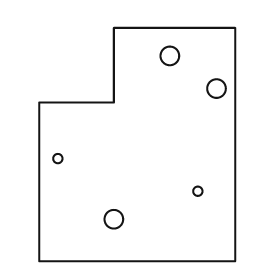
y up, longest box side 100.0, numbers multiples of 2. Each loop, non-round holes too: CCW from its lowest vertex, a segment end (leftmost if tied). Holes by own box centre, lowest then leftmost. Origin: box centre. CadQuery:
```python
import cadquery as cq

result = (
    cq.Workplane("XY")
    .moveTo(-42.0, -50.0)
    .lineTo(42.0, -50.0)
    .lineTo(42.0, 50.0)
    .lineTo(-10.0, 50.0)
    .lineTo(-10.0, 18.0)
    .lineTo(-42.0, 18.0)
    .close()
    .moveTo(-10.0, -32.0)
    .circle(4.0)
    .moveTo(26.0, -20.0)
    .circle(2.0)
    .moveTo(-34.0, -6.0)
    .circle(2.0)
    .moveTo(34.0, 24.0)
    .circle(4.0)
    .moveTo(14.0, 38.0)
    .circle(4.0)
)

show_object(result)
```